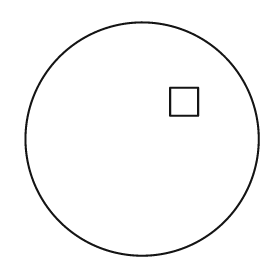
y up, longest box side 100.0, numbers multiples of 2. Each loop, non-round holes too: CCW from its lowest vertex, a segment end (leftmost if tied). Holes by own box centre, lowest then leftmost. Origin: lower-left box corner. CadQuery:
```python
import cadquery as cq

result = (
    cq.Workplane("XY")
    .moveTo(50.0, 50.0)
    .circle(50.0)
    .moveTo(62.0, 60.0)
    .lineTo(74.0, 60.0)
    .lineTo(74.0, 72.0)
    .lineTo(62.0, 72.0)
    .close()
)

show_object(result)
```